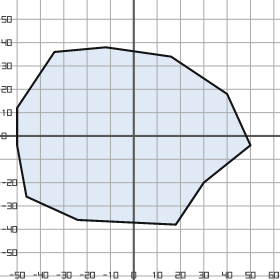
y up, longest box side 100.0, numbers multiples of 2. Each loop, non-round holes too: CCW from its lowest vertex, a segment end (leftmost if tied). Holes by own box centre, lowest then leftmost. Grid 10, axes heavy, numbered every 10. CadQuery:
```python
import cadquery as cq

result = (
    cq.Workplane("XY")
    .moveTo(18.0, -38.0)
    .lineTo(30.0, -20.0)
    .lineTo(50.0, -4.0)
    .lineTo(40.0, 18.0)
    .lineTo(16.0, 34.0)
    .lineTo(-12.0, 38.0)
    .lineTo(-34.0, 36.0)
    .lineTo(-50.0, 12.0)
    .lineTo(-50.0, -4.0)
    .lineTo(-46.0, -26.0)
    .lineTo(-24.0, -36.0)
    .close()
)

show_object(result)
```